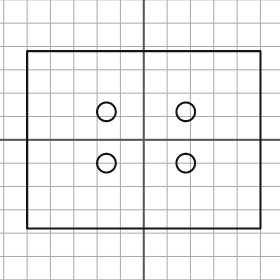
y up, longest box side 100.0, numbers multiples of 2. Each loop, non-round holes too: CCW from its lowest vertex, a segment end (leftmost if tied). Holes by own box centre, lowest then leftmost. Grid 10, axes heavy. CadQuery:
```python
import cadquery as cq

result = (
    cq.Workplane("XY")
    .moveTo(-50.0, -38.0)
    .lineTo(50.0, -38.0)
    .lineTo(50.0, 38.0)
    .lineTo(-50.0, 38.0)
    .close()
    .moveTo(-16.0, -10.0)
    .circle(4.0)
    .moveTo(18.0, -10.0)
    .circle(4.0)
    .moveTo(-16.0, 12.0)
    .circle(4.0)
    .moveTo(18.0, 12.0)
    .circle(4.0)
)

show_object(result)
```